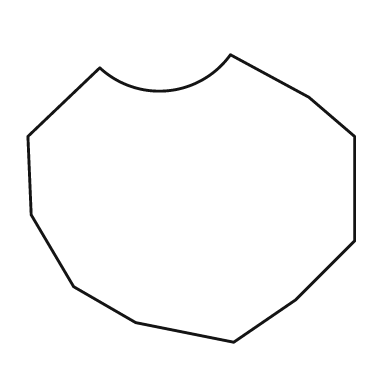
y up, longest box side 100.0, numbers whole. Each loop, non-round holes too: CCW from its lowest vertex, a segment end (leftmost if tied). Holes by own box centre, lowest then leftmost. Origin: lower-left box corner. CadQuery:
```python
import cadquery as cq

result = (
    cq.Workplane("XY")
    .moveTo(63.0, 0.0)
    .lineTo(82.0, 13.0)
    .lineTo(100.0, 31.0)
    .lineTo(100.0, 63.0)
    .lineTo(86.0, 75.0)
    .lineTo(62.0, 88.0)
    .threePointArc((43.0, 77.0), (22.0, 84.0))
    .lineTo(0.0, 63.0)
    .lineTo(1.0, 39.0)
    .lineTo(14.0, 17.0)
    .lineTo(33.0, 6.0)
    .close()
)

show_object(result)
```